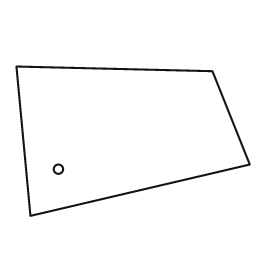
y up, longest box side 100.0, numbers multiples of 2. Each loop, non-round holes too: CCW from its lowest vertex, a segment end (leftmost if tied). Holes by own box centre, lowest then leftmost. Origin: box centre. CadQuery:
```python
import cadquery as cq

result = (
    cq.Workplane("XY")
    .moveTo(-44.0, -32.0)
    .lineTo(50.0, -10.0)
    .lineTo(34.0, 30.0)
    .lineTo(-50.0, 32.0)
    .close()
    .moveTo(-32.0, -12.0)
    .circle(2.0)
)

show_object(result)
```